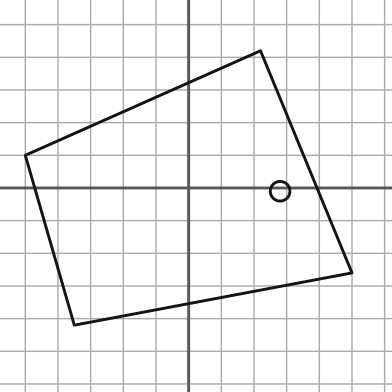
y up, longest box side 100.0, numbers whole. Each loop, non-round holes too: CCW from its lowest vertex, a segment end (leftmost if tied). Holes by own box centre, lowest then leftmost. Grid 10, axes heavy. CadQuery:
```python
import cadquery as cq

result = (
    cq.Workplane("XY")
    .moveTo(-35.0, -42.0)
    .lineTo(50.0, -26.0)
    .lineTo(22.0, 42.0)
    .lineTo(-50.0, 10.0)
    .close()
    .moveTo(28.0, -1.0)
    .circle(3.0)
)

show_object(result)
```